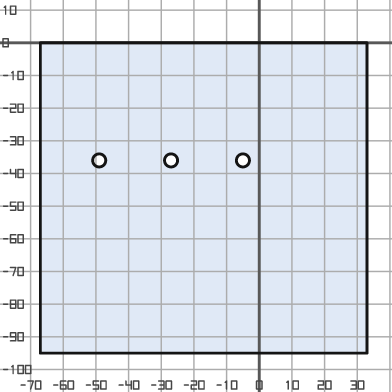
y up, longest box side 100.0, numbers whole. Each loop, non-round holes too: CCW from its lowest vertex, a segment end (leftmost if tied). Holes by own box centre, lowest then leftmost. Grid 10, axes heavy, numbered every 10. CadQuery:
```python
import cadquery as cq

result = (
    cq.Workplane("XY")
    .moveTo(-67.0, -95.0)
    .lineTo(33.0, -95.0)
    .lineTo(33.0, 0.0)
    .lineTo(-67.0, 0.0)
    .close()
    .moveTo(-49.0, -36.0)
    .circle(2.0)
    .moveTo(-27.0, -36.0)
    .circle(2.0)
    .moveTo(-5.0, -36.0)
    .circle(2.0)
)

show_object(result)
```